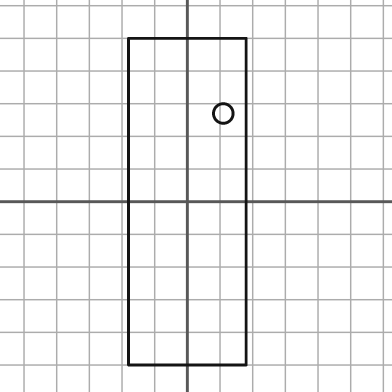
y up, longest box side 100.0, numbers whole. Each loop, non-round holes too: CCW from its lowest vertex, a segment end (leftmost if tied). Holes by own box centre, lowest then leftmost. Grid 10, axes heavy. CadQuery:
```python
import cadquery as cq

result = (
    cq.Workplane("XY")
    .moveTo(-18.0, -50.0)
    .lineTo(18.0, -50.0)
    .lineTo(18.0, 50.0)
    .lineTo(-18.0, 50.0)
    .close()
    .moveTo(11.0, 27.0)
    .circle(3.0)
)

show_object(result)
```